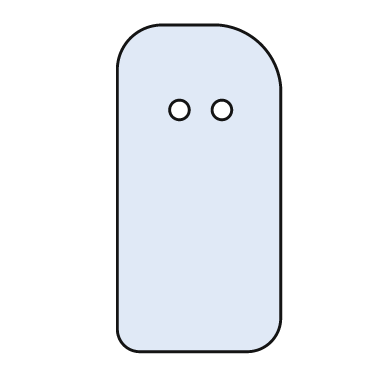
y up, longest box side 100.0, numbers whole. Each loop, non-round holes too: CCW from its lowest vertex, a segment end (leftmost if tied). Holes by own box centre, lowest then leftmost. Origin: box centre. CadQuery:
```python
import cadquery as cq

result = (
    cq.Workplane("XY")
    .moveTo(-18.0, -50.0)
    .lineTo(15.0, -50.0)
    .threePointArc((22.0, -47.0), (25.0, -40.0))
    .lineTo(25.0, 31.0)
    .threePointArc((19.0, 44.0), (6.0, 50.0))
    .lineTo(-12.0, 50.0)
    .threePointArc((-21.0, 46.0), (-25.0, 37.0))
    .lineTo(-25.0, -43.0)
    .threePointArc((-23.0, -48.0), (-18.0, -50.0))
    .close()
    .moveTo(-6.0, 24.0)
    .circle(3.0)
    .moveTo(7.0, 24.0)
    .circle(3.0)
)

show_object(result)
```